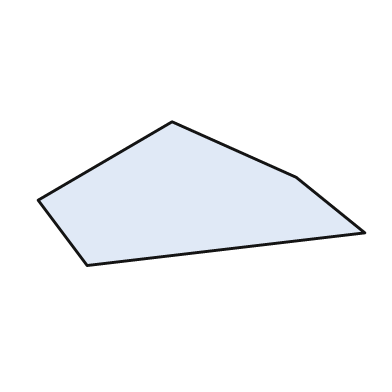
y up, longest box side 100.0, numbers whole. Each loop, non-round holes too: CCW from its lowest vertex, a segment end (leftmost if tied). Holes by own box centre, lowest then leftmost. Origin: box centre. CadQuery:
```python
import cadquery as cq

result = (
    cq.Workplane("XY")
    .moveTo(-35.0, -22.0)
    .lineTo(50.0, -12.0)
    .lineTo(29.0, 5.0)
    .lineTo(-9.0, 22.0)
    .lineTo(-50.0, -2.0)
    .close()
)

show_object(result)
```